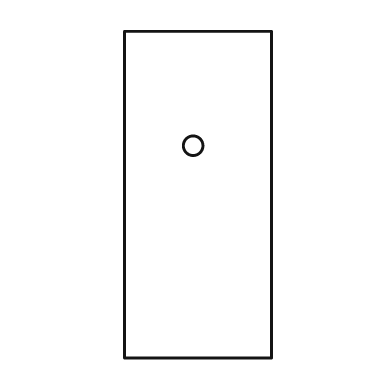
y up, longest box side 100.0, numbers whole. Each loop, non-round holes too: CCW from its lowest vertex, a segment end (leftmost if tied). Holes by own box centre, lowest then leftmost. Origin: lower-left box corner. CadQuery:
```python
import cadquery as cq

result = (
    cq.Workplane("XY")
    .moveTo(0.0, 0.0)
    .lineTo(45.0, 0.0)
    .lineTo(45.0, 100.0)
    .lineTo(0.0, 100.0)
    .close()
    .moveTo(21.0, 65.0)
    .circle(3.0)
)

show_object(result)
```